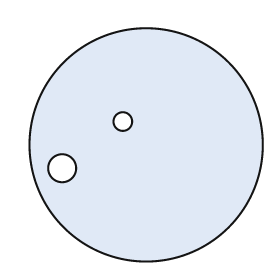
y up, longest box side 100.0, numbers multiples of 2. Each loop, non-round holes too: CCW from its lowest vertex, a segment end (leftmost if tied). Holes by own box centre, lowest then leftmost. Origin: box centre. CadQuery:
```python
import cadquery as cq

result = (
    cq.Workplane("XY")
    .moveTo(0.0, 0.0)
    .circle(50.0)
    .moveTo(-36.0, -10.0)
    .circle(6.0)
    .moveTo(-10.0, 10.0)
    .circle(4.0)
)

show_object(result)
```